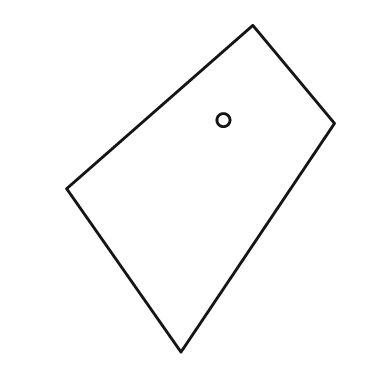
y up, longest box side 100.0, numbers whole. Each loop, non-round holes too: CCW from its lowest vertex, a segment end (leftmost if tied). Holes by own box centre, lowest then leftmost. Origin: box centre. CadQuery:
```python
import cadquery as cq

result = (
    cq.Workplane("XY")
    .moveTo(-6.0, -50.0)
    .lineTo(41.0, 20.0)
    .lineTo(16.0, 50.0)
    .lineTo(-41.0, 0.0)
    .close()
    .moveTo(7.0, 21.0)
    .circle(2.0)
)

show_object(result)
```